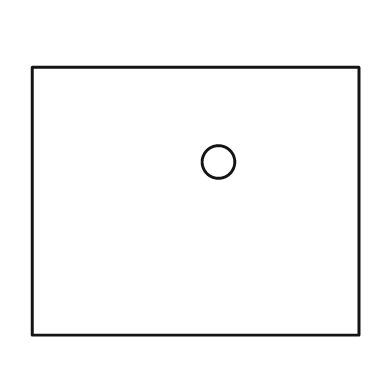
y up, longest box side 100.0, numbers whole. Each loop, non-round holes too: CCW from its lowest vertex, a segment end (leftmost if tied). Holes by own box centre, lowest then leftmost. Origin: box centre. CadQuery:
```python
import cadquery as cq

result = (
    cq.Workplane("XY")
    .moveTo(-50.0, -41.0)
    .lineTo(50.0, -41.0)
    .lineTo(50.0, 41.0)
    .lineTo(-50.0, 41.0)
    .close()
    .moveTo(7.0, 12.0)
    .circle(5.0)
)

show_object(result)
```